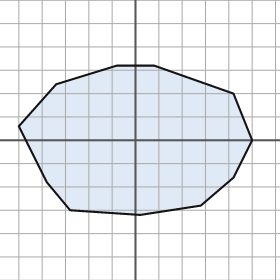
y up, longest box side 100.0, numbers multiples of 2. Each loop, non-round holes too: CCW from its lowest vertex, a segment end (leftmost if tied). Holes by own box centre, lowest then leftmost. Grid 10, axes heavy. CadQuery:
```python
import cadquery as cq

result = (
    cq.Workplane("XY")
    .moveTo(2.0, -32.0)
    .lineTo(28.0, -28.0)
    .lineTo(42.0, -16.0)
    .lineTo(50.0, 0.0)
    .lineTo(42.0, 20.0)
    .lineTo(8.0, 32.0)
    .lineTo(-8.0, 32.0)
    .lineTo(-34.0, 24.0)
    .lineTo(-50.0, 6.0)
    .lineTo(-38.0, -18.0)
    .lineTo(-28.0, -30.0)
    .close()
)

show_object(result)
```